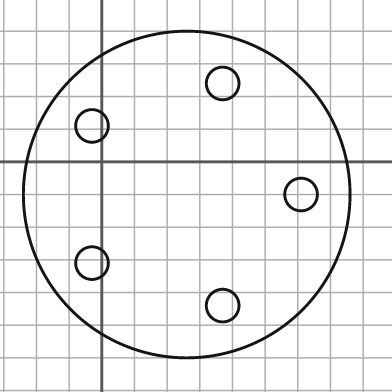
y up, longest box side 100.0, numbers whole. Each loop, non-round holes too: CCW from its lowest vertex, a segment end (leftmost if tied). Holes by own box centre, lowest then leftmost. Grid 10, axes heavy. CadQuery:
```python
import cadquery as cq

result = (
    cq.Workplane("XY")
    .moveTo(26.0, -10.0)
    .circle(50.0)
    .moveTo(37.0, -44.0)
    .circle(5.0)
    .moveTo(-3.0, -31.0)
    .circle(5.0)
    .moveTo(61.0, -10.0)
    .circle(5.0)
    .moveTo(-3.0, 11.0)
    .circle(5.0)
    .moveTo(37.0, 24.0)
    .circle(5.0)
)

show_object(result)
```